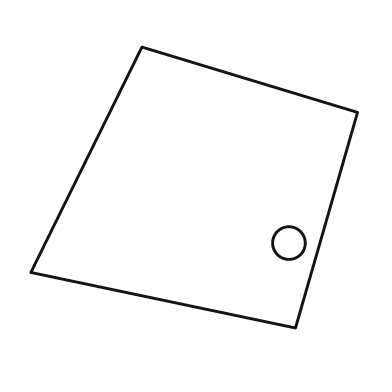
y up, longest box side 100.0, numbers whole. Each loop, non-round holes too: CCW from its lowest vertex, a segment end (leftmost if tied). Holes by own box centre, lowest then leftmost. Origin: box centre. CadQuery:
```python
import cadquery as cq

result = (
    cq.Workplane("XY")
    .moveTo(31.0, -43.0)
    .lineTo(50.0, 23.0)
    .lineTo(-16.0, 43.0)
    .lineTo(-50.0, -26.0)
    .close()
    .moveTo(29.0, -17.0)
    .circle(5.0)
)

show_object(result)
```